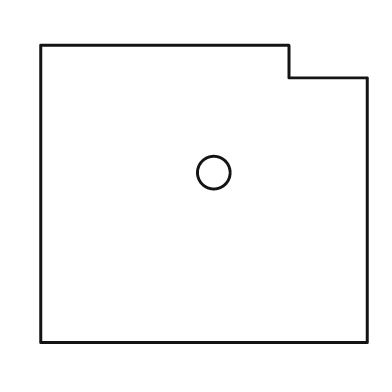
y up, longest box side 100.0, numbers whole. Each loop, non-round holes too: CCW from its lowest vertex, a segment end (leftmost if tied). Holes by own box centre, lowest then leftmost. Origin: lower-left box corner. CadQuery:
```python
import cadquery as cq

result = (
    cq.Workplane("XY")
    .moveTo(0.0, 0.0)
    .lineTo(100.0, 0.0)
    .lineTo(100.0, 81.0)
    .lineTo(76.0, 81.0)
    .lineTo(76.0, 91.0)
    .lineTo(0.0, 91.0)
    .close()
    .moveTo(53.0, 52.0)
    .circle(5.0)
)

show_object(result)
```